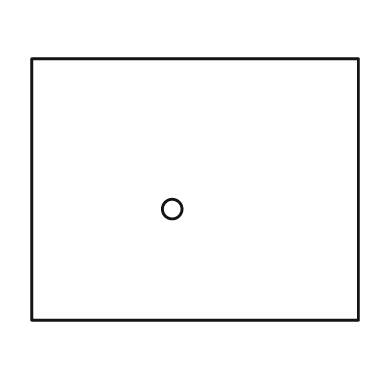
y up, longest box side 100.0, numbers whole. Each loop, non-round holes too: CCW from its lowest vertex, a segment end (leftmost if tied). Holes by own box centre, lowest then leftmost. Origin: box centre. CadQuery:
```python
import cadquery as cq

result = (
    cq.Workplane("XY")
    .moveTo(-50.0, -40.0)
    .lineTo(50.0, -40.0)
    .lineTo(50.0, 40.0)
    .lineTo(-50.0, 40.0)
    .close()
    .moveTo(-7.0, -6.0)
    .circle(3.0)
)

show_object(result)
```